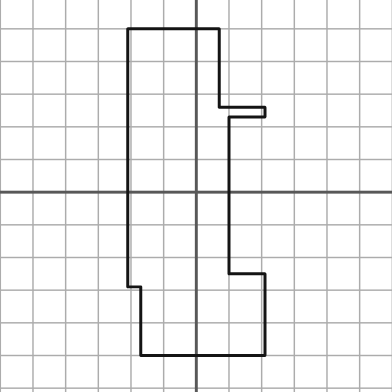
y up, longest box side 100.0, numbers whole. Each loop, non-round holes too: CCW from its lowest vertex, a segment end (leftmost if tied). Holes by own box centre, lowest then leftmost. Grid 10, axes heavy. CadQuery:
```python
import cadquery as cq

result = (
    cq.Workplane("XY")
    .moveTo(-17.0, -50.0)
    .lineTo(21.0, -50.0)
    .lineTo(21.0, -25.0)
    .lineTo(10.0, -25.0)
    .lineTo(10.0, 23.0)
    .lineTo(21.0, 23.0)
    .lineTo(21.0, 26.0)
    .lineTo(7.0, 26.0)
    .lineTo(7.0, 50.0)
    .lineTo(-21.0, 50.0)
    .lineTo(-21.0, -29.0)
    .lineTo(-17.0, -29.0)
    .close()
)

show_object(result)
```